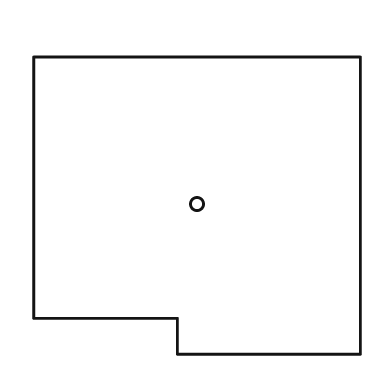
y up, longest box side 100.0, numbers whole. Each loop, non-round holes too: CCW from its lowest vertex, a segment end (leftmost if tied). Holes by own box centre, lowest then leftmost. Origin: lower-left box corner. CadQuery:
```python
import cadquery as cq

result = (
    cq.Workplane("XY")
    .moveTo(44.0, 0.0)
    .lineTo(100.0, 0.0)
    .lineTo(100.0, 91.0)
    .lineTo(0.0, 91.0)
    .lineTo(0.0, 11.0)
    .lineTo(44.0, 11.0)
    .close()
    .moveTo(50.0, 46.0)
    .circle(2.0)
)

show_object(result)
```